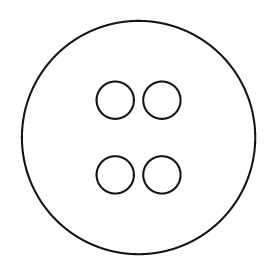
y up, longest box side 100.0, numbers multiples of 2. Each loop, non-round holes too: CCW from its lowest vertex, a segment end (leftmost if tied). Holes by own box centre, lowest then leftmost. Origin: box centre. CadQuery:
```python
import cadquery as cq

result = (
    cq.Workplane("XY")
    .moveTo(0.0, 0.0)
    .circle(50.0)
    .moveTo(-10.0, -16.0)
    .circle(8.0)
    .moveTo(10.0, -16.0)
    .circle(8.0)
    .moveTo(-10.0, 16.0)
    .circle(8.0)
    .moveTo(10.0, 16.0)
    .circle(8.0)
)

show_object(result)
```